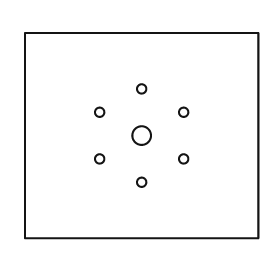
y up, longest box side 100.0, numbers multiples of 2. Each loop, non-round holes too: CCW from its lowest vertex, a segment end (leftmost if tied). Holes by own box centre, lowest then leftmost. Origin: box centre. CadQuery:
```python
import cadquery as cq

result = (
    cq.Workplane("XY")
    .moveTo(-50.0, -44.0)
    .lineTo(50.0, -44.0)
    .lineTo(50.0, 44.0)
    .lineTo(-50.0, 44.0)
    .close()
    .moveTo(0.0, -20.0)
    .circle(2.0)
    .moveTo(-18.0, -10.0)
    .circle(2.0)
    .moveTo(18.0, -10.0)
    .circle(2.0)
    .moveTo(0.0, 0.0)
    .circle(4.0)
    .moveTo(-18.0, 10.0)
    .circle(2.0)
    .moveTo(18.0, 10.0)
    .circle(2.0)
    .moveTo(0.0, 20.0)
    .circle(2.0)
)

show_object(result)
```